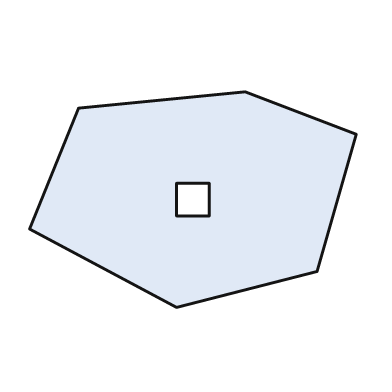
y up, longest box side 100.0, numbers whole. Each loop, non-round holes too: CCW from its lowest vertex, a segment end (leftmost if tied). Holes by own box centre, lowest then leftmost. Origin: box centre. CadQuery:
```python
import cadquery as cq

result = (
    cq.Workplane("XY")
    .moveTo(-5.0, -33.0)
    .lineTo(38.0, -22.0)
    .lineTo(50.0, 20.0)
    .lineTo(16.0, 33.0)
    .lineTo(-35.0, 28.0)
    .lineTo(-50.0, -9.0)
    .close()
    .moveTo(-5.0, -5.0)
    .lineTo(5.0, -5.0)
    .lineTo(5.0, 5.0)
    .lineTo(-5.0, 5.0)
    .close()
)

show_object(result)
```